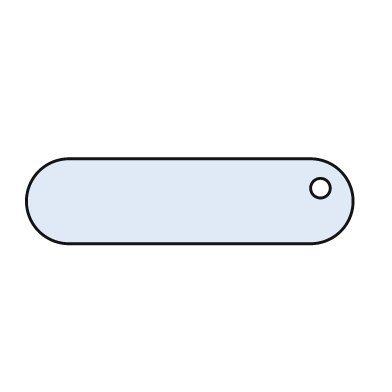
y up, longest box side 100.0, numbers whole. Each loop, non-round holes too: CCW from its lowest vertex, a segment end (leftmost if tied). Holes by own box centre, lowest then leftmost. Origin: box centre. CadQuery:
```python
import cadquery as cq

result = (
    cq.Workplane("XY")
    .moveTo(-37.0, -13.0)
    .lineTo(37.0, -13.0)
    .threePointArc((50.0, 0.0), (37.0, 13.0))
    .lineTo(-37.0, 13.0)
    .threePointArc((-50.0, 0.0), (-37.0, -13.0))
    .close()
    .moveTo(40.0, 4.0)
    .circle(3.0)
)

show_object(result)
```